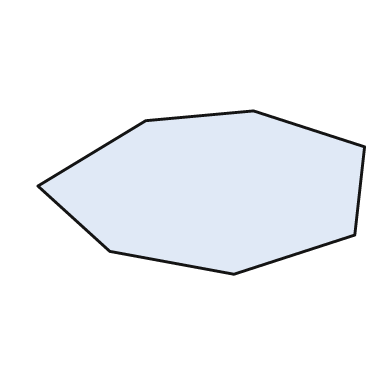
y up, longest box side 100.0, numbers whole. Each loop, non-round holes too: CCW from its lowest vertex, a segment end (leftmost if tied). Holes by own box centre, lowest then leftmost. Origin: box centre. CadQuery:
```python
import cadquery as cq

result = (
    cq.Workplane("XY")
    .moveTo(10.0, -25.0)
    .lineTo(47.0, -13.0)
    .lineTo(50.0, 14.0)
    .lineTo(16.0, 25.0)
    .lineTo(-17.0, 22.0)
    .lineTo(-50.0, 2.0)
    .lineTo(-28.0, -18.0)
    .close()
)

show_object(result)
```